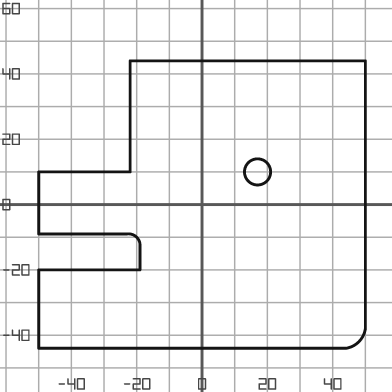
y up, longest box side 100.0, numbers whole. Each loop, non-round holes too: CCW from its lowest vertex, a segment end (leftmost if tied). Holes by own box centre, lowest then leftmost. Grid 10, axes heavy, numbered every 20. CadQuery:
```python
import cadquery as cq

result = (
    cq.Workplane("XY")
    .moveTo(-50.0, -44.0)
    .lineTo(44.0, -44.0)
    .threePointArc((48.0, -42.0), (50.0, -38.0))
    .lineTo(50.0, 44.0)
    .lineTo(-22.0, 44.0)
    .lineTo(-22.0, 10.0)
    .lineTo(-50.0, 10.0)
    .lineTo(-50.0, -9.0)
    .lineTo(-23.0, -9.0)
    .threePointArc((-20.0, -10.0), (-19.0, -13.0))
    .lineTo(-19.0, -20.0)
    .lineTo(-50.0, -20.0)
    .close()
    .moveTo(17.0, 10.0)
    .circle(4.0)
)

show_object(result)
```